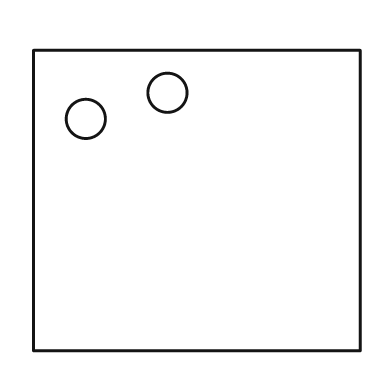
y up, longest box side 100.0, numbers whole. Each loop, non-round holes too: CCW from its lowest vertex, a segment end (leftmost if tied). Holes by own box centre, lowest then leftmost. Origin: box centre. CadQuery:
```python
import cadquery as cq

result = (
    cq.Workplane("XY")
    .moveTo(-50.0, -46.0)
    .lineTo(50.0, -46.0)
    .lineTo(50.0, 46.0)
    .lineTo(-50.0, 46.0)
    .close()
    .moveTo(-34.0, 25.0)
    .circle(6.0)
    .moveTo(-9.0, 33.0)
    .circle(6.0)
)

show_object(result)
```